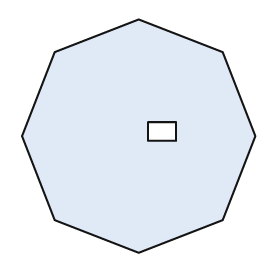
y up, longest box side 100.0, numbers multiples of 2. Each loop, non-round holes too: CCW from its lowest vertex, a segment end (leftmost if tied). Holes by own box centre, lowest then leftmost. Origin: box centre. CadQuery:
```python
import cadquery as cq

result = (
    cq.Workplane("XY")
    .moveTo(0.0, -50.0)
    .lineTo(36.0, -36.0)
    .lineTo(50.0, 0.0)
    .lineTo(36.0, 36.0)
    .lineTo(0.0, 50.0)
    .lineTo(-36.0, 36.0)
    .lineTo(-50.0, 0.0)
    .lineTo(-36.0, -36.0)
    .close()
    .moveTo(4.0, -2.0)
    .lineTo(16.0, -2.0)
    .lineTo(16.0, 6.0)
    .lineTo(4.0, 6.0)
    .close()
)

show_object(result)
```